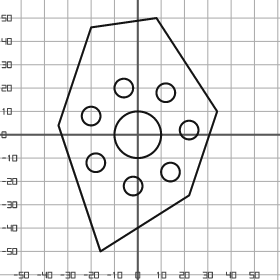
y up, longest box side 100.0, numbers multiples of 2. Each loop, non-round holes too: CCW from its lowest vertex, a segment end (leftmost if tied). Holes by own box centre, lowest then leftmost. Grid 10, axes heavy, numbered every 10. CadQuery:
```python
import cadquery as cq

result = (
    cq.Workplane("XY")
    .moveTo(-16.0, -50.0)
    .lineTo(22.0, -26.0)
    .lineTo(34.0, 10.0)
    .lineTo(8.0, 50.0)
    .lineTo(-20.0, 46.0)
    .lineTo(-34.0, 4.0)
    .close()
    .moveTo(-2.0, -22.0)
    .circle(4.0)
    .moveTo(14.0, -16.0)
    .circle(4.0)
    .moveTo(-18.0, -12.0)
    .circle(4.0)
    .moveTo(0.0, 0.0)
    .circle(10.0)
    .moveTo(22.0, 2.0)
    .circle(4.0)
    .moveTo(-20.0, 8.0)
    .circle(4.0)
    .moveTo(12.0, 18.0)
    .circle(4.0)
    .moveTo(-6.0, 20.0)
    .circle(4.0)
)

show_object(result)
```